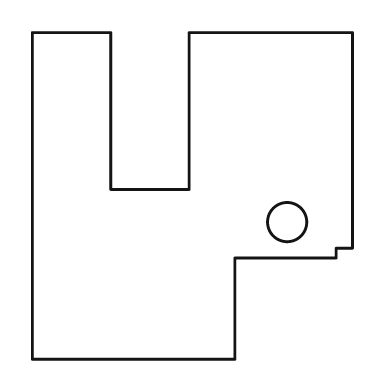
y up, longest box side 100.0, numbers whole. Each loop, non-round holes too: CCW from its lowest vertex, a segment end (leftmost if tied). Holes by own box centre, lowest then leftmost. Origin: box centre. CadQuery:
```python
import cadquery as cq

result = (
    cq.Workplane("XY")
    .moveTo(-49.0, -50.0)
    .lineTo(13.0, -50.0)
    .lineTo(13.0, -19.0)
    .lineTo(44.0, -19.0)
    .lineTo(44.0, -16.0)
    .lineTo(49.0, -16.0)
    .lineTo(49.0, 50.0)
    .lineTo(-1.0, 50.0)
    .lineTo(-1.0, 2.0)
    .lineTo(-25.0, 2.0)
    .lineTo(-25.0, 50.0)
    .lineTo(-49.0, 50.0)
    .close()
    .moveTo(29.0, -8.0)
    .circle(6.0)
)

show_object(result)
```